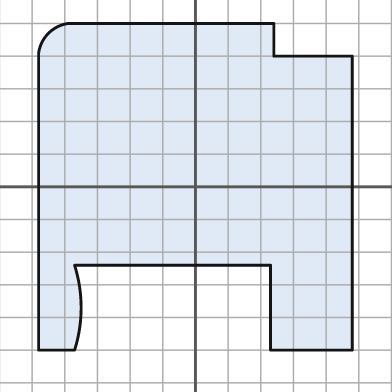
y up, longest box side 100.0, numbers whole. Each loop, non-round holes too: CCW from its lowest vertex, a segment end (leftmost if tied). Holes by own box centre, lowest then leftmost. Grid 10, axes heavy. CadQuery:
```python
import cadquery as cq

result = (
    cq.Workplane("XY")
    .moveTo(-48.0, -50.0)
    .lineTo(-37.0, -50.0)
    .threePointArc((-35.0, -37.0), (-37.0, -24.0))
    .lineTo(23.0, -24.0)
    .lineTo(23.0, -50.0)
    .lineTo(48.0, -50.0)
    .lineTo(48.0, 40.0)
    .lineTo(24.0, 40.0)
    .lineTo(24.0, 50.0)
    .lineTo(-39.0, 50.0)
    .threePointArc((-45.0, 47.0), (-48.0, 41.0))
    .close()
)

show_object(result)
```